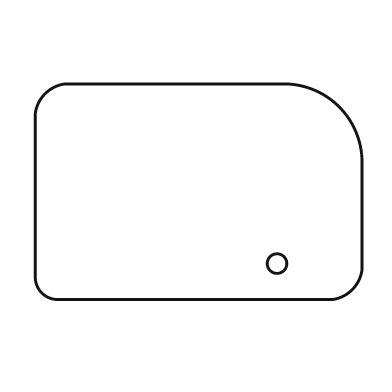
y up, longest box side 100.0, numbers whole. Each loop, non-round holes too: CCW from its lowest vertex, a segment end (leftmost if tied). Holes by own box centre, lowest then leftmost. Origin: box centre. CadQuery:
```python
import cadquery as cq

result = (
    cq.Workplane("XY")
    .moveTo(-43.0, -33.0)
    .lineTo(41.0, -33.0)
    .threePointArc((47.0, -30.0), (50.0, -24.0))
    .lineTo(50.0, 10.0)
    .threePointArc((43.0, 26.0), (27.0, 33.0))
    .lineTo(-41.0, 33.0)
    .threePointArc((-47.0, 30.0), (-50.0, 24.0))
    .lineTo(-50.0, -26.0)
    .threePointArc((-48.0, -31.0), (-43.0, -33.0))
    .close()
    .moveTo(24.0, -22.0)
    .circle(3.0)
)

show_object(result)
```